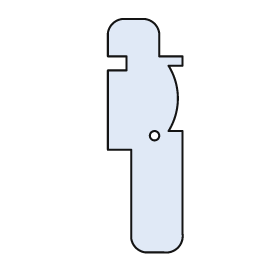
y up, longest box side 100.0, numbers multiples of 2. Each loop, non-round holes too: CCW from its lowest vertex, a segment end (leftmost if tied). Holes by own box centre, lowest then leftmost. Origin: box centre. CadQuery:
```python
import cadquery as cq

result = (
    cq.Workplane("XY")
    .moveTo(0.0, -50.0)
    .lineTo(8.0, -50.0)
    .threePointArc((14.0, -48.0), (16.0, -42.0))
    .lineTo(16.0, 2.0)
    .lineTo(10.0, 2.0)
    .threePointArc((14.0, 16.0), (10.0, 30.0))
    .lineTo(16.0, 30.0)
    .lineTo(16.0, 34.0)
    .lineTo(6.0, 34.0)
    .lineTo(6.0, 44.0)
    .threePointArc((4.0, 48.0), (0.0, 50.0))
    .lineTo(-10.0, 50.0)
    .threePointArc((-14.0, 48.0), (-16.0, 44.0))
    .lineTo(-16.0, 34.0)
    .lineTo(-8.0, 34.0)
    .lineTo(-8.0, 28.0)
    .lineTo(-16.0, 28.0)
    .lineTo(-16.0, -6.0)
    .lineTo(-6.0, -6.0)
    .lineTo(-6.0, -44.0)
    .threePointArc((-4.0, -48.0), (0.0, -50.0))
    .close()
    .moveTo(4.0, 0.0)
    .circle(2.0)
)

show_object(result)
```